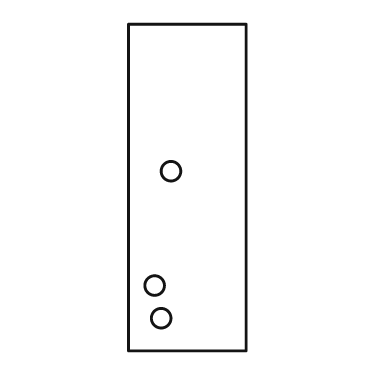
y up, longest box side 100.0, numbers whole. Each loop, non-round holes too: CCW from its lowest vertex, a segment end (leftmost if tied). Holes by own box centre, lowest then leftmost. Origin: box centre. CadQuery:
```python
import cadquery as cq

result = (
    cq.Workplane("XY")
    .moveTo(-18.0, -50.0)
    .lineTo(18.0, -50.0)
    .lineTo(18.0, 50.0)
    .lineTo(-18.0, 50.0)
    .close()
    .moveTo(-8.0, -40.0)
    .circle(3.0)
    .moveTo(-10.0, -30.0)
    .circle(3.0)
    .moveTo(-5.0, 5.0)
    .circle(3.0)
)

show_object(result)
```